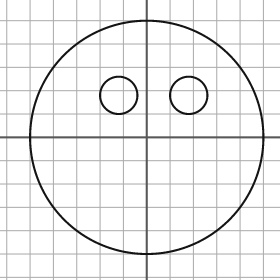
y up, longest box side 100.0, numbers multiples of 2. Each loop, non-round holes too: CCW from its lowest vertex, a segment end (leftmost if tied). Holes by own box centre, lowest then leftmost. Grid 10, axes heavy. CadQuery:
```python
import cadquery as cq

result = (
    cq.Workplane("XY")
    .moveTo(0.0, 0.0)
    .circle(50.0)
    .moveTo(-12.0, 18.0)
    .circle(8.0)
    .moveTo(18.0, 18.0)
    .circle(8.0)
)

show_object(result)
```